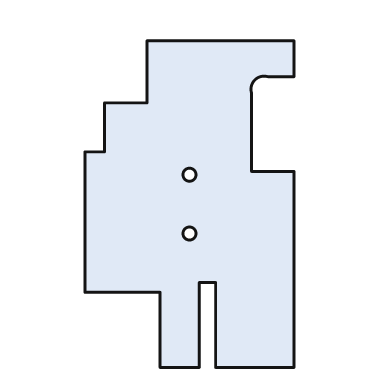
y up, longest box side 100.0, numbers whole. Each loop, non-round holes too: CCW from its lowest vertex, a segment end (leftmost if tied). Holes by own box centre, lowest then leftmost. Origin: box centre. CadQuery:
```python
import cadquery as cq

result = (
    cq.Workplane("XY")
    .moveTo(-9.0, -50.0)
    .lineTo(3.0, -50.0)
    .lineTo(3.0, -24.0)
    .lineTo(8.0, -24.0)
    .lineTo(8.0, -50.0)
    .lineTo(32.0, -50.0)
    .lineTo(32.0, 10.0)
    .lineTo(19.0, 10.0)
    .lineTo(19.0, 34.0)
    .threePointArc((20.0, 38.0), (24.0, 39.0))
    .lineTo(32.0, 39.0)
    .lineTo(32.0, 50.0)
    .lineTo(-13.0, 50.0)
    .lineTo(-13.0, 31.0)
    .lineTo(-26.0, 31.0)
    .lineTo(-26.0, 16.0)
    .lineTo(-32.0, 16.0)
    .lineTo(-32.0, -27.0)
    .lineTo(-9.0, -27.0)
    .close()
    .moveTo(0.0, -9.0)
    .circle(2.0)
    .moveTo(0.0, 9.0)
    .circle(2.0)
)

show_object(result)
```